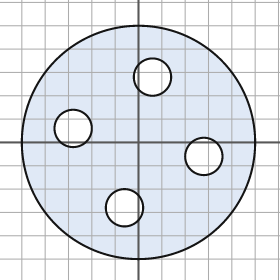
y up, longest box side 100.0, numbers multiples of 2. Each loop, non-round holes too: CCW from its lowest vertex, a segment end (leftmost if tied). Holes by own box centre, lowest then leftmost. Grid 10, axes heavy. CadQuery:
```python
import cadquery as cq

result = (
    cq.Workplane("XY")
    .moveTo(0.0, 0.0)
    .circle(50.0)
    .moveTo(-6.0, -28.0)
    .circle(8.0)
    .moveTo(28.0, -6.0)
    .circle(8.0)
    .moveTo(-28.0, 6.0)
    .circle(8.0)
    .moveTo(6.0, 28.0)
    .circle(8.0)
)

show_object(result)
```